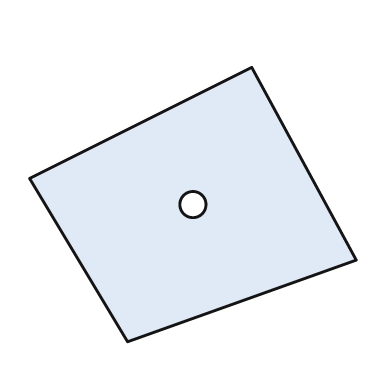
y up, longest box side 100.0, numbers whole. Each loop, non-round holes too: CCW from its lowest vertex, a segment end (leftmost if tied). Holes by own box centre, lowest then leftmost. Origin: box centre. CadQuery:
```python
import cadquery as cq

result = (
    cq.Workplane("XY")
    .moveTo(-20.0, -42.0)
    .lineTo(50.0, -17.0)
    .lineTo(18.0, 42.0)
    .lineTo(-50.0, 8.0)
    .close()
    .moveTo(0.0, 0.0)
    .circle(4.0)
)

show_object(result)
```